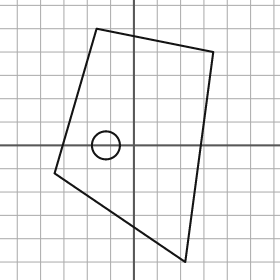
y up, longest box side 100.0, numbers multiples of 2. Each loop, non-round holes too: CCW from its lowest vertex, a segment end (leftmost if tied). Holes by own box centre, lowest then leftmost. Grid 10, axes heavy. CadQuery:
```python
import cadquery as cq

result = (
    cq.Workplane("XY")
    .moveTo(22.0, -50.0)
    .lineTo(34.0, 40.0)
    .lineTo(-16.0, 50.0)
    .lineTo(-34.0, -12.0)
    .close()
    .moveTo(-12.0, 0.0)
    .circle(6.0)
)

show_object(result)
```